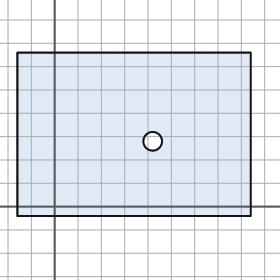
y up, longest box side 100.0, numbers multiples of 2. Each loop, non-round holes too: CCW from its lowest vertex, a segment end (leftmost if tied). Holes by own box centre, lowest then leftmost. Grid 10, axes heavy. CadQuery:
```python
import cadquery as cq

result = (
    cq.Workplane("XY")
    .moveTo(-16.0, -4.0)
    .lineTo(84.0, -4.0)
    .lineTo(84.0, 66.0)
    .lineTo(-16.0, 66.0)
    .close()
    .moveTo(42.0, 28.0)
    .circle(4.0)
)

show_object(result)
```